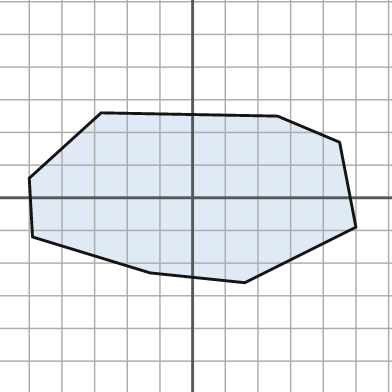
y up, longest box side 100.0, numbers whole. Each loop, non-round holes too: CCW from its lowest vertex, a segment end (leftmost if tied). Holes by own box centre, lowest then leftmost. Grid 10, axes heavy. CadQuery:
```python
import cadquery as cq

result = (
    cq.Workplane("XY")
    .moveTo(16.0, -26.0)
    .lineTo(50.0, -9.0)
    .lineTo(45.0, 17.0)
    .lineTo(26.0, 25.0)
    .lineTo(-28.0, 26.0)
    .lineTo(-50.0, 6.0)
    .lineTo(-49.0, -12.0)
    .lineTo(-13.0, -23.0)
    .close()
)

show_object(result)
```